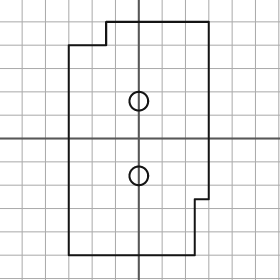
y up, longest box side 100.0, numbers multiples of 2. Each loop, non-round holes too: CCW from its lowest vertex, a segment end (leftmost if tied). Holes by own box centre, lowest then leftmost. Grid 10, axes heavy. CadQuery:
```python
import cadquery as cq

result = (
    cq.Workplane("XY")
    .moveTo(-30.0, -50.0)
    .lineTo(24.0, -50.0)
    .lineTo(24.0, -26.0)
    .lineTo(30.0, -26.0)
    .lineTo(30.0, 50.0)
    .lineTo(-14.0, 50.0)
    .lineTo(-14.0, 40.0)
    .lineTo(-30.0, 40.0)
    .close()
    .moveTo(0.0, -16.0)
    .circle(4.0)
    .moveTo(0.0, 16.0)
    .circle(4.0)
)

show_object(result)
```